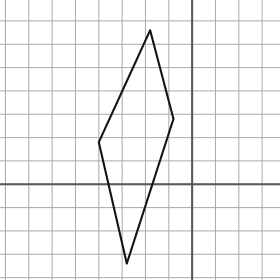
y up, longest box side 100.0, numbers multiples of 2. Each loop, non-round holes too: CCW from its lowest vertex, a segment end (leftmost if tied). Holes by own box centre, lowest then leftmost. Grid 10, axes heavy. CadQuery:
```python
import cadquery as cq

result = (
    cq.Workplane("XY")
    .moveTo(-28.0, -34.0)
    .lineTo(-8.0, 28.0)
    .lineTo(-18.0, 66.0)
    .lineTo(-40.0, 18.0)
    .close()
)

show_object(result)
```